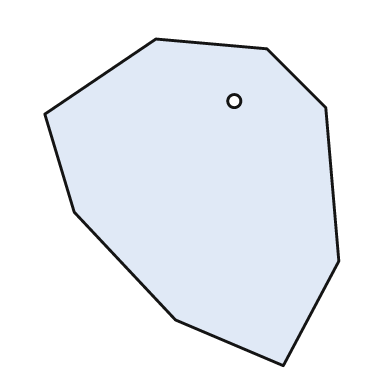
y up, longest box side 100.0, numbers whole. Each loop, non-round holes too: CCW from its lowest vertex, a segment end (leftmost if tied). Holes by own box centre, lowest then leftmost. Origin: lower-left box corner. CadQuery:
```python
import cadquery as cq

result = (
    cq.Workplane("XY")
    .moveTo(73.0, 0.0)
    .lineTo(90.0, 32.0)
    .lineTo(86.0, 79.0)
    .lineTo(68.0, 97.0)
    .lineTo(34.0, 100.0)
    .lineTo(0.0, 77.0)
    .lineTo(9.0, 47.0)
    .lineTo(40.0, 14.0)
    .close()
    .moveTo(58.0, 81.0)
    .circle(2.0)
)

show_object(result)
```